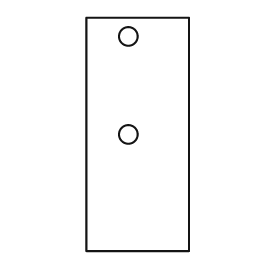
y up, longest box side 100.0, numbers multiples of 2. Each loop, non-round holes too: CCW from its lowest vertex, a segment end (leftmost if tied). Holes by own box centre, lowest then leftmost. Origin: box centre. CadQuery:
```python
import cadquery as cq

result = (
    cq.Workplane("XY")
    .moveTo(-22.0, -50.0)
    .lineTo(22.0, -50.0)
    .lineTo(22.0, 50.0)
    .lineTo(-22.0, 50.0)
    .close()
    .moveTo(-4.0, 0.0)
    .circle(4.0)
    .moveTo(-4.0, 42.0)
    .circle(4.0)
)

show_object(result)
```